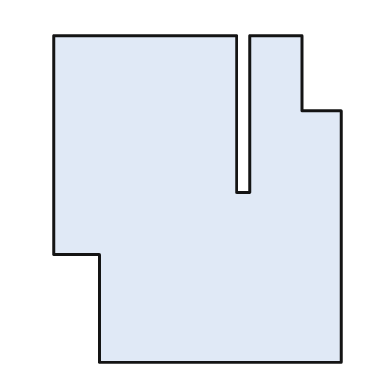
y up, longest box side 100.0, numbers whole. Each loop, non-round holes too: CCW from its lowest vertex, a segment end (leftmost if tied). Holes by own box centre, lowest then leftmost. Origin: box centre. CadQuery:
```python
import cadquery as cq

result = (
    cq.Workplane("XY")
    .moveTo(-30.0, -50.0)
    .lineTo(44.0, -50.0)
    .lineTo(44.0, 27.0)
    .lineTo(32.0, 27.0)
    .lineTo(32.0, 50.0)
    .lineTo(16.0, 50.0)
    .lineTo(16.0, 2.0)
    .lineTo(12.0, 2.0)
    .lineTo(12.0, 50.0)
    .lineTo(-44.0, 50.0)
    .lineTo(-44.0, -17.0)
    .lineTo(-30.0, -17.0)
    .close()
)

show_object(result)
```